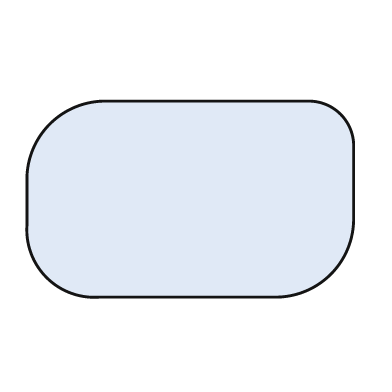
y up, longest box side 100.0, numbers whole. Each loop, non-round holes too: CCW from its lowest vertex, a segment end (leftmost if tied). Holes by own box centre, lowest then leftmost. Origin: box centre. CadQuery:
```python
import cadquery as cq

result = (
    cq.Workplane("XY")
    .moveTo(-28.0, -30.0)
    .lineTo(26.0, -30.0)
    .threePointArc((43.0, -23.0), (50.0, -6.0))
    .lineTo(50.0, 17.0)
    .threePointArc((46.0, 26.0), (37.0, 30.0))
    .lineTo(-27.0, 30.0)
    .threePointArc((-43.0, 23.0), (-50.0, 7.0))
    .lineTo(-50.0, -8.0)
    .threePointArc((-44.0, -24.0), (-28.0, -30.0))
    .close()
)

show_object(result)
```